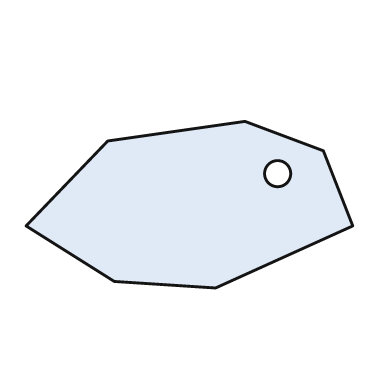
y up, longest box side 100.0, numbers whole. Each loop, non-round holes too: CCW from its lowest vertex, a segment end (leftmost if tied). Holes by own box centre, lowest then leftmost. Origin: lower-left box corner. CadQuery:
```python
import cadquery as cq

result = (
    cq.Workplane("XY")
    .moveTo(58.0, 0.0)
    .lineTo(100.0, 19.0)
    .lineTo(91.0, 42.0)
    .lineTo(67.0, 51.0)
    .lineTo(25.0, 45.0)
    .lineTo(0.0, 19.0)
    .lineTo(27.0, 2.0)
    .close()
    .moveTo(77.0, 35.0)
    .circle(4.0)
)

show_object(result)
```